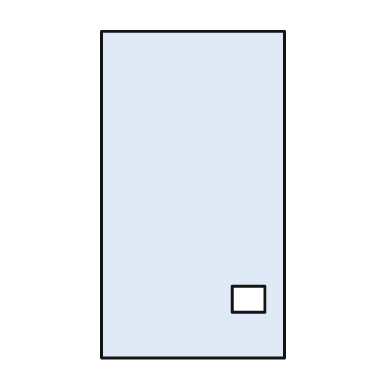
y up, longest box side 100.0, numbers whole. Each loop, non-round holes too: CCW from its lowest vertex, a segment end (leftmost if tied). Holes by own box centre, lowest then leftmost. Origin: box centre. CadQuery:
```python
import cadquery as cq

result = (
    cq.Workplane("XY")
    .moveTo(-28.0, -50.0)
    .lineTo(28.0, -50.0)
    .lineTo(28.0, 50.0)
    .lineTo(-28.0, 50.0)
    .close()
    .moveTo(12.0, -36.0)
    .lineTo(22.0, -36.0)
    .lineTo(22.0, -28.0)
    .lineTo(12.0, -28.0)
    .close()
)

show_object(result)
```